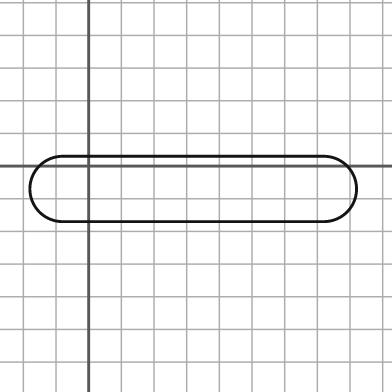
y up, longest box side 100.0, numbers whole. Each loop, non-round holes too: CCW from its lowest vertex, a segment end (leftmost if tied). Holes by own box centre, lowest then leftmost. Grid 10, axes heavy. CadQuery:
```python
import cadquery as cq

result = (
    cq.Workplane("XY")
    .moveTo(-8.0, -17.0)
    .lineTo(72.0, -17.0)
    .threePointArc((82.0, -7.0), (72.0, 3.0))
    .lineTo(-8.0, 3.0)
    .threePointArc((-18.0, -7.0), (-8.0, -17.0))
    .close()
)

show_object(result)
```